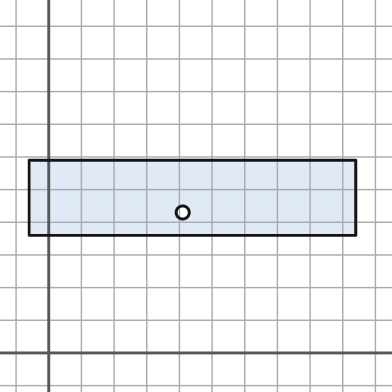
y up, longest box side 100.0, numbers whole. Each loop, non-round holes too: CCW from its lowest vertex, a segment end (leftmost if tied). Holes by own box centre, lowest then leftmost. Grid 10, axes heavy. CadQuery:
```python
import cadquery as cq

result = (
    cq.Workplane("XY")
    .moveTo(-6.0, 36.0)
    .lineTo(94.0, 36.0)
    .lineTo(94.0, 59.0)
    .lineTo(-6.0, 59.0)
    .close()
    .moveTo(41.0, 43.0)
    .circle(2.0)
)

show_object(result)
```